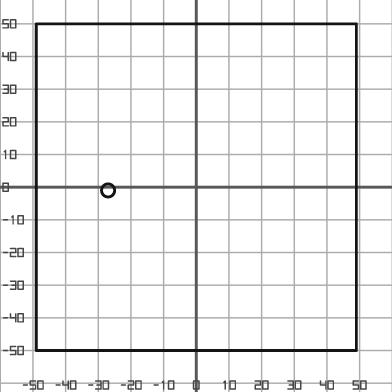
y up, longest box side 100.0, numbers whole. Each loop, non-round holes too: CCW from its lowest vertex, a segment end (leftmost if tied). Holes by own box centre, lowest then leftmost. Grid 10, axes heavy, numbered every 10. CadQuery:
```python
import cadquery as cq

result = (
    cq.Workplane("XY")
    .moveTo(-49.0, -50.0)
    .lineTo(49.0, -50.0)
    .lineTo(49.0, 50.0)
    .lineTo(-49.0, 50.0)
    .close()
    .moveTo(-27.0, -1.0)
    .circle(2.0)
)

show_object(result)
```